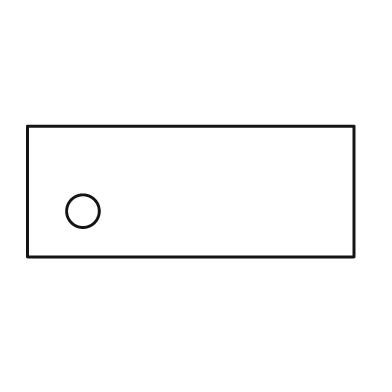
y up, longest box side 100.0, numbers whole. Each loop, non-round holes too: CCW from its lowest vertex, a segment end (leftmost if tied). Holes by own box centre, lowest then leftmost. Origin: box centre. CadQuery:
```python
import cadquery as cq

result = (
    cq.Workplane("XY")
    .moveTo(-50.0, -20.0)
    .lineTo(50.0, -20.0)
    .lineTo(50.0, 20.0)
    .lineTo(-50.0, 20.0)
    .close()
    .moveTo(-33.0, -6.0)
    .circle(5.0)
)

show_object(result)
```